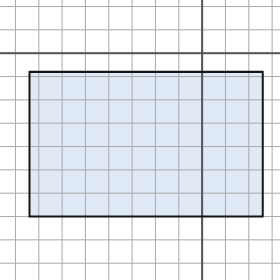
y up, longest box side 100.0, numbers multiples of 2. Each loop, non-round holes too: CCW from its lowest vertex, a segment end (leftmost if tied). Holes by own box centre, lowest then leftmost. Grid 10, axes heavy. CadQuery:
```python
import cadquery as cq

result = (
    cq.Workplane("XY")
    .moveTo(-74.0, -70.0)
    .lineTo(26.0, -70.0)
    .lineTo(26.0, -8.0)
    .lineTo(-74.0, -8.0)
    .close()
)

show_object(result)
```